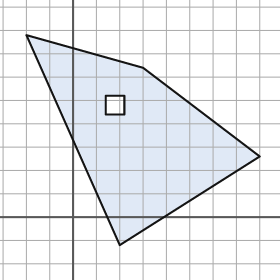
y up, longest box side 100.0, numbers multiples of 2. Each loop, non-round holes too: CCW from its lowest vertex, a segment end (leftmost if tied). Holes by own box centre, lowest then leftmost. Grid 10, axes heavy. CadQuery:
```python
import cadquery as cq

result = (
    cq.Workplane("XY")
    .moveTo(20.0, -12.0)
    .lineTo(80.0, 26.0)
    .lineTo(30.0, 64.0)
    .lineTo(-20.0, 78.0)
    .close()
    .moveTo(14.0, 44.0)
    .lineTo(22.0, 44.0)
    .lineTo(22.0, 52.0)
    .lineTo(14.0, 52.0)
    .close()
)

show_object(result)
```